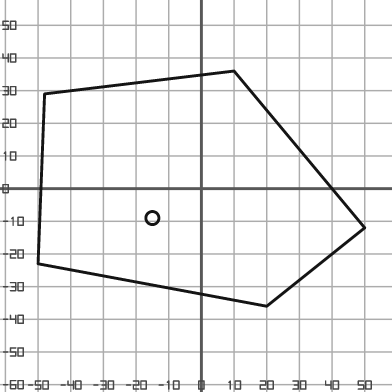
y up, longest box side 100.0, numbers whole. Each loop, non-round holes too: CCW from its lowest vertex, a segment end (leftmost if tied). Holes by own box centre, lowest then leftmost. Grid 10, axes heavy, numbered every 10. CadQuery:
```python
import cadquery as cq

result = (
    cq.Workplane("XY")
    .moveTo(20.0, -36.0)
    .lineTo(50.0, -12.0)
    .lineTo(10.0, 36.0)
    .lineTo(-48.0, 29.0)
    .lineTo(-50.0, -23.0)
    .close()
    .moveTo(-15.0, -9.0)
    .circle(2.0)
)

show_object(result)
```